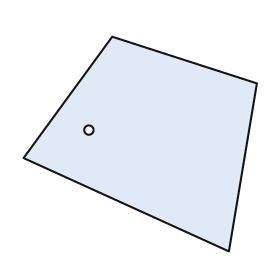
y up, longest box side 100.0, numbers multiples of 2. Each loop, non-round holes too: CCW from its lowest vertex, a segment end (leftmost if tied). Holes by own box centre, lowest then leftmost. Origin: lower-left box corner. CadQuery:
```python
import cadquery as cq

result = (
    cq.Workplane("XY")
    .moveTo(88.0, 0.0)
    .lineTo(100.0, 72.0)
    .lineTo(38.0, 92.0)
    .lineTo(0.0, 40.0)
    .close()
    .moveTo(28.0, 52.0)
    .circle(2.0)
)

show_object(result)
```